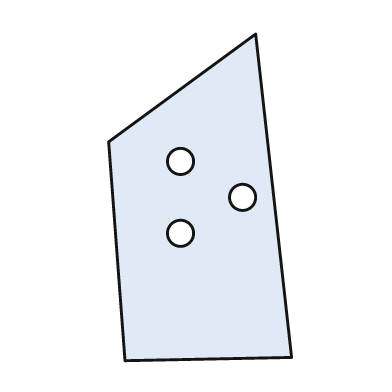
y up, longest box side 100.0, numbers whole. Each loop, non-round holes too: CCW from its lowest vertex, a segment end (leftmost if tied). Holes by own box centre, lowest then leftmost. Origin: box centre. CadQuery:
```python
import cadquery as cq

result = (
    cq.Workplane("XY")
    .moveTo(-23.0, -50.0)
    .lineTo(28.0, -49.0)
    .lineTo(17.0, 50.0)
    .lineTo(-28.0, 17.0)
    .close()
    .moveTo(-6.0, -11.0)
    .circle(4.0)
    .moveTo(13.0, 0.0)
    .circle(4.0)
    .moveTo(-6.0, 11.0)
    .circle(4.0)
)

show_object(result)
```